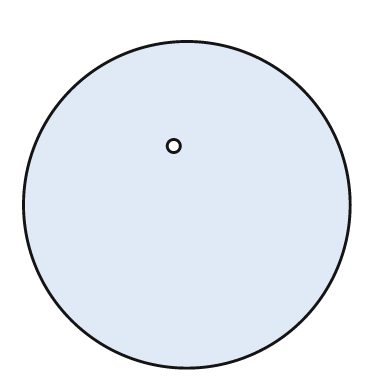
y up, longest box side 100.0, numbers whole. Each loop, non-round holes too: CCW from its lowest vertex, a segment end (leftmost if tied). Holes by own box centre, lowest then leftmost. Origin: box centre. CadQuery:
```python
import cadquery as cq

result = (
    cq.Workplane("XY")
    .moveTo(0.0, 0.0)
    .circle(50.0)
    .moveTo(-4.0, 18.0)
    .circle(2.0)
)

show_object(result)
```